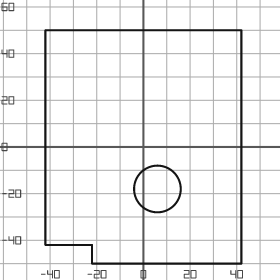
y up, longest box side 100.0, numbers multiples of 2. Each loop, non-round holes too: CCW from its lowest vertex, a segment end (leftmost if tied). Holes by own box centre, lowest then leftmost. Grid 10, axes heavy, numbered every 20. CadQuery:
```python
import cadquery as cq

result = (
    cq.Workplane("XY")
    .moveTo(-22.0, -50.0)
    .lineTo(42.0, -50.0)
    .lineTo(42.0, 50.0)
    .lineTo(-42.0, 50.0)
    .lineTo(-42.0, -42.0)
    .lineTo(-22.0, -42.0)
    .close()
    .moveTo(6.0, -18.0)
    .circle(10.0)
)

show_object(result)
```